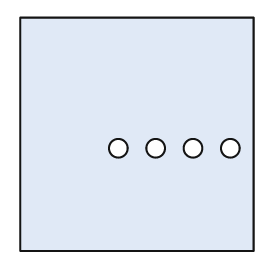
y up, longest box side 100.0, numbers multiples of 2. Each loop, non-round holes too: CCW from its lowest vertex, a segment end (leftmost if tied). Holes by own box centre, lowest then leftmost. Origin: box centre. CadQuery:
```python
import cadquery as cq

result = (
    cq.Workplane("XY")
    .moveTo(-50.0, -50.0)
    .lineTo(50.0, -50.0)
    .lineTo(50.0, 50.0)
    .lineTo(-50.0, 50.0)
    .close()
    .moveTo(-8.0, -6.0)
    .circle(4.0)
    .moveTo(8.0, -6.0)
    .circle(4.0)
    .moveTo(24.0, -6.0)
    .circle(4.0)
    .moveTo(40.0, -6.0)
    .circle(4.0)
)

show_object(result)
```